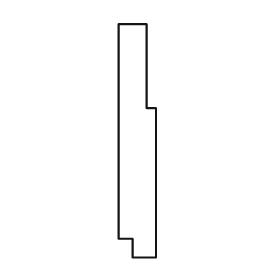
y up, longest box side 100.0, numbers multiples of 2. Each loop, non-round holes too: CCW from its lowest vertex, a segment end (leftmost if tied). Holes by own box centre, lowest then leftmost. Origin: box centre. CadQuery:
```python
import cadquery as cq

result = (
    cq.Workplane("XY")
    .moveTo(-2.0, -50.0)
    .lineTo(8.0, -50.0)
    .lineTo(8.0, 14.0)
    .lineTo(4.0, 14.0)
    .lineTo(4.0, 50.0)
    .lineTo(-8.0, 50.0)
    .lineTo(-8.0, -42.0)
    .lineTo(-2.0, -42.0)
    .close()
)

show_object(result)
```